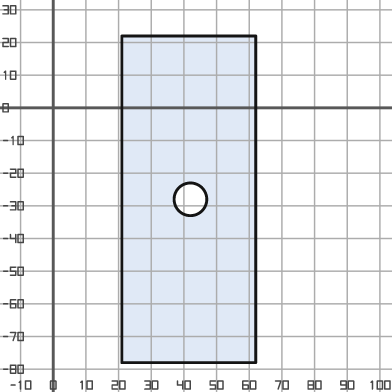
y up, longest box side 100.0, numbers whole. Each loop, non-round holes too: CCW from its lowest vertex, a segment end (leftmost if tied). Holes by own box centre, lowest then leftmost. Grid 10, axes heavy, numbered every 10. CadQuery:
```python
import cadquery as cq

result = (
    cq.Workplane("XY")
    .moveTo(21.0, -78.0)
    .lineTo(62.0, -78.0)
    .lineTo(62.0, 22.0)
    .lineTo(21.0, 22.0)
    .close()
    .moveTo(42.0, -28.0)
    .circle(5.0)
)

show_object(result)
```